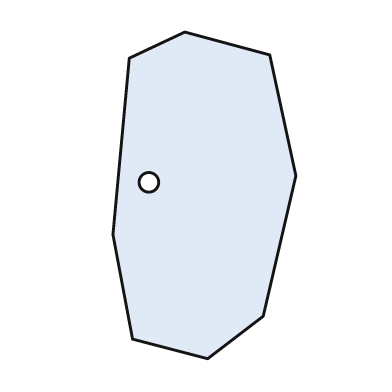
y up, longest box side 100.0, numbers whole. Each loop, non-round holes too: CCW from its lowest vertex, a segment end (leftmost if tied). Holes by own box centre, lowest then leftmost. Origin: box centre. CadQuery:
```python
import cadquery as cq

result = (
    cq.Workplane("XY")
    .moveTo(1.0, -50.0)
    .lineTo(18.0, -37.0)
    .lineTo(28.0, 6.0)
    .lineTo(20.0, 43.0)
    .lineTo(-6.0, 50.0)
    .lineTo(-23.0, 42.0)
    .lineTo(-28.0, -12.0)
    .lineTo(-22.0, -44.0)
    .close()
    .moveTo(-17.0, 4.0)
    .circle(3.0)
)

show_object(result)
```